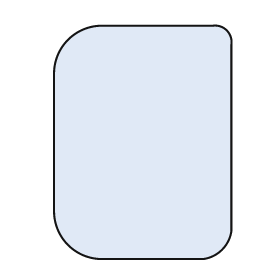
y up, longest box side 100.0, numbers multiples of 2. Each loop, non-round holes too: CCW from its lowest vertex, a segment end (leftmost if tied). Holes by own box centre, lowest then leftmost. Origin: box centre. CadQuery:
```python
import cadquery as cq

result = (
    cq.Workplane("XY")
    .moveTo(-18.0, -50.0)
    .lineTo(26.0, -50.0)
    .threePointArc((34.0, -46.0), (38.0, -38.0))
    .lineTo(38.0, 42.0)
    .threePointArc((36.0, 48.0), (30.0, 50.0))
    .lineTo(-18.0, 50.0)
    .threePointArc((-32.0, 44.0), (-38.0, 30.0))
    .lineTo(-38.0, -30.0)
    .threePointArc((-32.0, -44.0), (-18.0, -50.0))
    .close()
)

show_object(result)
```